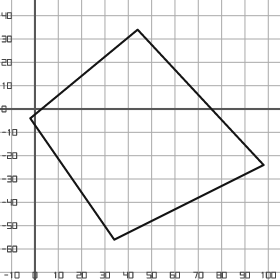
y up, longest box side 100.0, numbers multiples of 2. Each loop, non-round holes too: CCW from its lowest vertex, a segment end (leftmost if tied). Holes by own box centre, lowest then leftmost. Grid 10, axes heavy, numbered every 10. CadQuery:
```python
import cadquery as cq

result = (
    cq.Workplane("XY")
    .moveTo(34.0, -56.0)
    .lineTo(98.0, -24.0)
    .lineTo(44.0, 34.0)
    .lineTo(-2.0, -4.0)
    .close()
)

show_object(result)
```